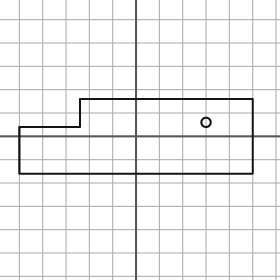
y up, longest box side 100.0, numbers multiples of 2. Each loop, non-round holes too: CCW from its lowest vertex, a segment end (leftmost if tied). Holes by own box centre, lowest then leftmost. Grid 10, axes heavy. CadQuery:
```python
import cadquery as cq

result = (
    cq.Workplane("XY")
    .moveTo(-50.0, -16.0)
    .lineTo(50.0, -16.0)
    .lineTo(50.0, 16.0)
    .lineTo(-24.0, 16.0)
    .lineTo(-24.0, 4.0)
    .lineTo(-50.0, 4.0)
    .close()
    .moveTo(30.0, 6.0)
    .circle(2.0)
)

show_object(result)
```